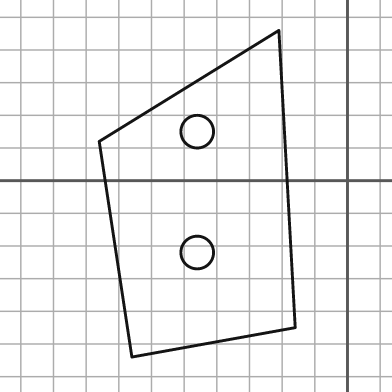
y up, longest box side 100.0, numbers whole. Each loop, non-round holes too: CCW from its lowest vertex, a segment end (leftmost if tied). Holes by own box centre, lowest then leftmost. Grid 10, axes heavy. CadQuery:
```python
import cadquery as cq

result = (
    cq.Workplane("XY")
    .moveTo(-66.0, -54.0)
    .lineTo(-16.0, -45.0)
    .lineTo(-21.0, 46.0)
    .lineTo(-76.0, 12.0)
    .close()
    .moveTo(-46.0, -22.0)
    .circle(5.0)
    .moveTo(-46.0, 15.0)
    .circle(5.0)
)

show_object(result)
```